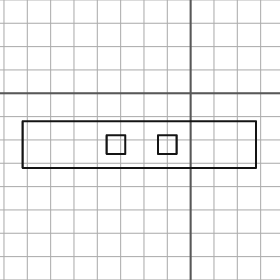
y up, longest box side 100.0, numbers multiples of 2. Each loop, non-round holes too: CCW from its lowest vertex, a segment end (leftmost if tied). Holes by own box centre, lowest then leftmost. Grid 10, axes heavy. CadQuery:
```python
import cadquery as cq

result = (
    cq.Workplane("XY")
    .moveTo(-72.0, -32.0)
    .lineTo(28.0, -32.0)
    .lineTo(28.0, -12.0)
    .lineTo(-72.0, -12.0)
    .close()
    .moveTo(-36.0, -26.0)
    .lineTo(-28.0, -26.0)
    .lineTo(-28.0, -18.0)
    .lineTo(-36.0, -18.0)
    .close()
    .moveTo(-14.0, -26.0)
    .lineTo(-6.0, -26.0)
    .lineTo(-6.0, -18.0)
    .lineTo(-14.0, -18.0)
    .close()
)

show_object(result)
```